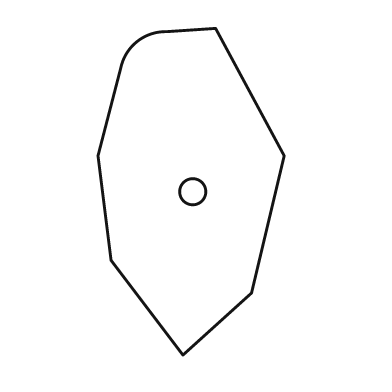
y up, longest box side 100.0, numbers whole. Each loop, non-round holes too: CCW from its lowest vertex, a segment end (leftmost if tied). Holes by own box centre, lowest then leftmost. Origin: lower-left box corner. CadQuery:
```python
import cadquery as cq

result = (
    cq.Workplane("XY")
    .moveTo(26.0, 0.0)
    .lineTo(47.0, 19.0)
    .lineTo(57.0, 61.0)
    .lineTo(36.0, 100.0)
    .lineTo(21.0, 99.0)
    .threePointArc((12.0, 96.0), (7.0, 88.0))
    .lineTo(0.0, 61.0)
    .lineTo(4.0, 29.0)
    .close()
    .moveTo(29.0, 50.0)
    .circle(4.0)
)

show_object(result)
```